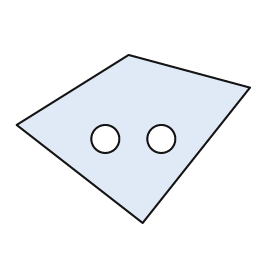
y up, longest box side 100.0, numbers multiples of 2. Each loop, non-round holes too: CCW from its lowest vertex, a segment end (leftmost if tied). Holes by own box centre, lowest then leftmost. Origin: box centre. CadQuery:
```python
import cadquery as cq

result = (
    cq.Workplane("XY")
    .moveTo(4.0, -36.0)
    .lineTo(50.0, 22.0)
    .lineTo(-2.0, 36.0)
    .lineTo(-50.0, 6.0)
    .close()
    .moveTo(-12.0, 0.0)
    .circle(6.0)
    .moveTo(12.0, 0.0)
    .circle(6.0)
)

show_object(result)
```